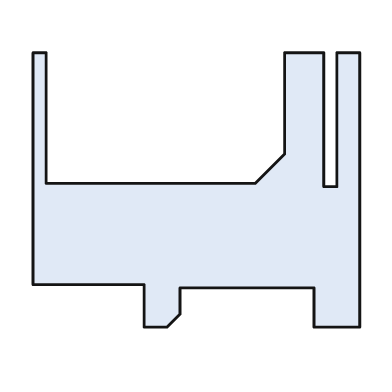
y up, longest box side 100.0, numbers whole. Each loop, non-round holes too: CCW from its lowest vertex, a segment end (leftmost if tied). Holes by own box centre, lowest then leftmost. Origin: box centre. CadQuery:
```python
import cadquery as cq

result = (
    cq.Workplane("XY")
    .moveTo(-16.0, -42.0)
    .lineTo(-9.0, -42.0)
    .lineTo(-5.0, -38.0)
    .lineTo(-5.0, -30.0)
    .lineTo(36.0, -30.0)
    .lineTo(36.0, -42.0)
    .lineTo(50.0, -42.0)
    .lineTo(50.0, 42.0)
    .lineTo(43.0, 42.0)
    .lineTo(43.0, 1.0)
    .lineTo(39.0, 1.0)
    .lineTo(39.0, 42.0)
    .lineTo(27.0, 42.0)
    .lineTo(27.0, 11.0)
    .lineTo(18.0, 2.0)
    .lineTo(-46.0, 2.0)
    .lineTo(-46.0, 42.0)
    .lineTo(-50.0, 42.0)
    .lineTo(-50.0, -29.0)
    .lineTo(-16.0, -29.0)
    .close()
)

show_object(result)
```